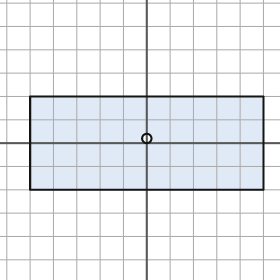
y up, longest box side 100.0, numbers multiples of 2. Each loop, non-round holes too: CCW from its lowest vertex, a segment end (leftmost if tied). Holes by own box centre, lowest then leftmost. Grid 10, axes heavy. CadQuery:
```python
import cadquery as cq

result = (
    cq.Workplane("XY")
    .moveTo(-50.0, -20.0)
    .lineTo(50.0, -20.0)
    .lineTo(50.0, 20.0)
    .lineTo(-50.0, 20.0)
    .close()
    .moveTo(0.0, 2.0)
    .circle(2.0)
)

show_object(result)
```